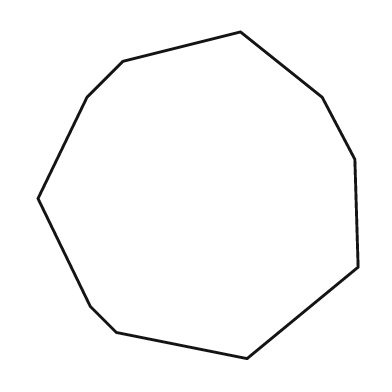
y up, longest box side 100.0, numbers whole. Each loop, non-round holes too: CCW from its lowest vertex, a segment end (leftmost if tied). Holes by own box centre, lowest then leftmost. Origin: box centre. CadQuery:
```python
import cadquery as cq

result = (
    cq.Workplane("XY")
    .moveTo(15.0, -50.0)
    .lineTo(49.0, -22.0)
    .lineTo(48.0, 11.0)
    .lineTo(38.0, 30.0)
    .lineTo(13.0, 50.0)
    .lineTo(-23.0, 41.0)
    .lineTo(-34.0, 30.0)
    .lineTo(-49.0, -1.0)
    .lineTo(-33.0, -34.0)
    .lineTo(-25.0, -42.0)
    .close()
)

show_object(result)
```